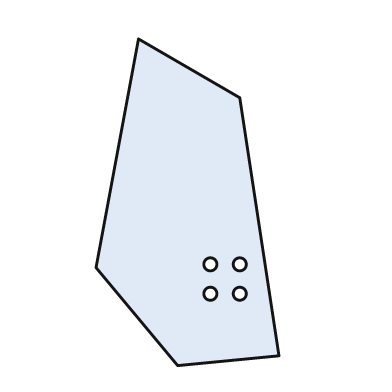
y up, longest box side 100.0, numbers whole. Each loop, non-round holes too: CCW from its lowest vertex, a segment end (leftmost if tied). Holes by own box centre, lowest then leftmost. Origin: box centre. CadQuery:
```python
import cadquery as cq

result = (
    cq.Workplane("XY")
    .moveTo(-3.0, -50.0)
    .lineTo(28.0, -47.0)
    .lineTo(16.0, 32.0)
    .lineTo(-15.0, 50.0)
    .lineTo(-28.0, -20.0)
    .close()
    .moveTo(7.0, -28.0)
    .circle(2.0)
    .moveTo(16.0, -28.0)
    .circle(2.0)
    .moveTo(7.0, -19.0)
    .circle(2.0)
    .moveTo(16.0, -19.0)
    .circle(2.0)
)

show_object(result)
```